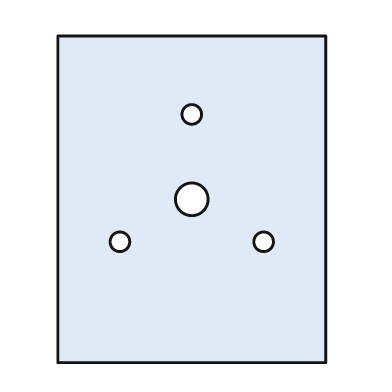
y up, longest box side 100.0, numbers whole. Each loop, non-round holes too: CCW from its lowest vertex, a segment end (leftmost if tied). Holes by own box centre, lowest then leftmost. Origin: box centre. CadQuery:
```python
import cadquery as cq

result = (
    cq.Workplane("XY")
    .moveTo(-41.0, -50.0)
    .lineTo(41.0, -50.0)
    .lineTo(41.0, 50.0)
    .lineTo(-41.0, 50.0)
    .close()
    .moveTo(-22.0, -13.0)
    .circle(3.0)
    .moveTo(22.0, -13.0)
    .circle(3.0)
    .moveTo(0.0, 0.0)
    .circle(5.0)
    .moveTo(0.0, 26.0)
    .circle(3.0)
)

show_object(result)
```